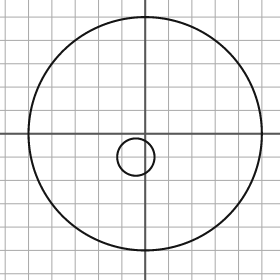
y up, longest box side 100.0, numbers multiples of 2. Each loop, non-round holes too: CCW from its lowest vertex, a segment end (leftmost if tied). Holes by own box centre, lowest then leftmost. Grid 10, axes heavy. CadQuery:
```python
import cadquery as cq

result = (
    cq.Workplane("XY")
    .moveTo(0.0, 0.0)
    .circle(50.0)
    .moveTo(-4.0, -10.0)
    .circle(8.0)
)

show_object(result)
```